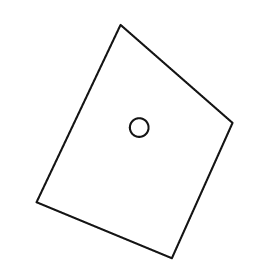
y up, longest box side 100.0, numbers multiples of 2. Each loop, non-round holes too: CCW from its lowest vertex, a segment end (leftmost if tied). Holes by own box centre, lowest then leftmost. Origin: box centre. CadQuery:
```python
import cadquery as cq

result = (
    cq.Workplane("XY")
    .moveTo(16.0, -50.0)
    .lineTo(42.0, 8.0)
    .lineTo(-6.0, 50.0)
    .lineTo(-42.0, -26.0)
    .close()
    .moveTo(2.0, 6.0)
    .circle(4.0)
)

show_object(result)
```